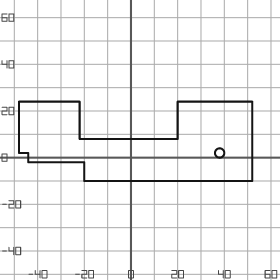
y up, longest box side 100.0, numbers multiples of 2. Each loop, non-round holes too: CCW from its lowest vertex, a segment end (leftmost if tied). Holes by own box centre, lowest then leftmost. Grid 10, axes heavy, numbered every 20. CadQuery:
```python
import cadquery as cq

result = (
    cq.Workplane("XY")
    .moveTo(-20.0, -10.0)
    .lineTo(52.0, -10.0)
    .lineTo(52.0, 24.0)
    .lineTo(20.0, 24.0)
    .lineTo(20.0, 8.0)
    .lineTo(-22.0, 8.0)
    .lineTo(-22.0, 24.0)
    .lineTo(-48.0, 24.0)
    .lineTo(-48.0, 2.0)
    .lineTo(-44.0, 2.0)
    .lineTo(-44.0, -2.0)
    .lineTo(-20.0, -2.0)
    .close()
    .moveTo(38.0, 2.0)
    .circle(2.0)
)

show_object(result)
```